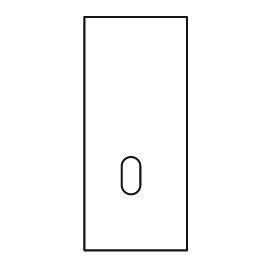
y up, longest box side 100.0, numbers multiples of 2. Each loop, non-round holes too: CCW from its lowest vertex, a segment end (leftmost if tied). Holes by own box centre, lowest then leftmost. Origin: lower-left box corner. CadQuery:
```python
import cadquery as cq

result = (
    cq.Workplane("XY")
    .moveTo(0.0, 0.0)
    .lineTo(44.0, 0.0)
    .lineTo(44.0, 100.0)
    .lineTo(0.0, 100.0)
    .close()
    .moveTo(16.0, 28.0)
    .threePointArc((20.0, 24.0), (24.0, 28.0))
    .lineTo(24.0, 36.0)
    .threePointArc((20.0, 40.0), (16.0, 36.0))
    .close()
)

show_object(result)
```